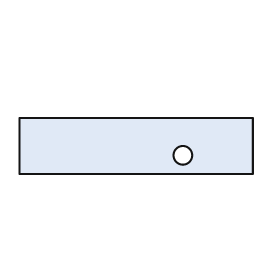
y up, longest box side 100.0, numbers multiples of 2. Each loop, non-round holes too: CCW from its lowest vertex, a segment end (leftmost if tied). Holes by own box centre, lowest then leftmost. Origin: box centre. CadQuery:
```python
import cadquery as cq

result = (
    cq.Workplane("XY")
    .moveTo(-50.0, -12.0)
    .lineTo(50.0, -12.0)
    .lineTo(50.0, 12.0)
    .lineTo(-50.0, 12.0)
    .close()
    .moveTo(20.0, -4.0)
    .circle(4.0)
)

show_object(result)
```